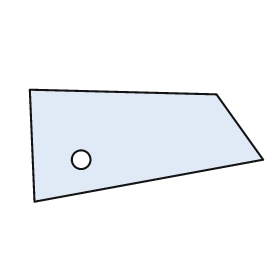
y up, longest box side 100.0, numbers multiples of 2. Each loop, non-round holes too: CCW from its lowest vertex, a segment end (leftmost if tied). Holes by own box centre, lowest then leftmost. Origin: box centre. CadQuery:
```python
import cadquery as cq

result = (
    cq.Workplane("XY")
    .moveTo(-48.0, -24.0)
    .lineTo(50.0, -6.0)
    .lineTo(30.0, 22.0)
    .lineTo(-50.0, 24.0)
    .close()
    .moveTo(-28.0, -6.0)
    .circle(4.0)
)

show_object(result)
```